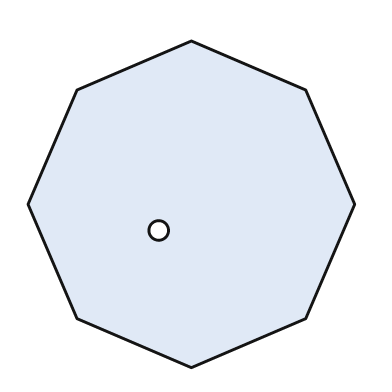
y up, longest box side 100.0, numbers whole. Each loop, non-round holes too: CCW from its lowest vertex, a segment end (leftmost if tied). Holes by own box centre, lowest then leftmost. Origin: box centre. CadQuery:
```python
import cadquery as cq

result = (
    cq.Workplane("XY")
    .moveTo(0.0, -50.0)
    .lineTo(35.0, -35.0)
    .lineTo(50.0, 0.0)
    .lineTo(35.0, 35.0)
    .lineTo(0.0, 50.0)
    .lineTo(-35.0, 35.0)
    .lineTo(-50.0, 0.0)
    .lineTo(-35.0, -35.0)
    .close()
    .moveTo(-10.0, -8.0)
    .circle(3.0)
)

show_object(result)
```